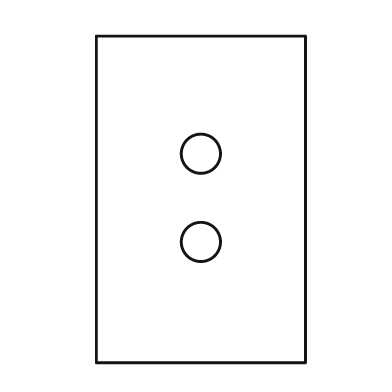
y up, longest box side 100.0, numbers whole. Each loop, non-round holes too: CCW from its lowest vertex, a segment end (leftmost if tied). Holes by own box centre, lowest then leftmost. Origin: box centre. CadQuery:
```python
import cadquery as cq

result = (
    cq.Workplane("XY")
    .moveTo(-32.0, -50.0)
    .lineTo(32.0, -50.0)
    .lineTo(32.0, 50.0)
    .lineTo(-32.0, 50.0)
    .close()
    .moveTo(0.0, -13.0)
    .circle(6.0)
    .moveTo(0.0, 14.0)
    .circle(6.0)
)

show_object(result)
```